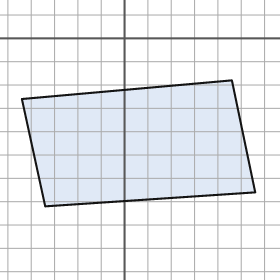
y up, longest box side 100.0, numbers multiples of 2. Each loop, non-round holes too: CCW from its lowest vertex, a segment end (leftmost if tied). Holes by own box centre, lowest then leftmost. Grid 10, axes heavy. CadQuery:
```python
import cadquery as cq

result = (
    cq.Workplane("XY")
    .moveTo(-34.0, -72.0)
    .lineTo(56.0, -66.0)
    .lineTo(46.0, -18.0)
    .lineTo(-44.0, -26.0)
    .close()
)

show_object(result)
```